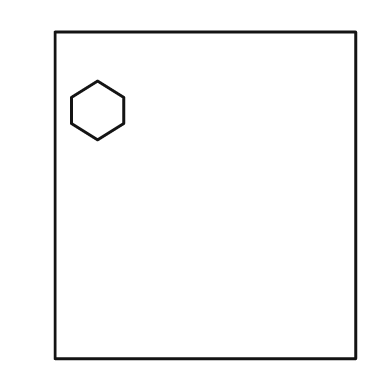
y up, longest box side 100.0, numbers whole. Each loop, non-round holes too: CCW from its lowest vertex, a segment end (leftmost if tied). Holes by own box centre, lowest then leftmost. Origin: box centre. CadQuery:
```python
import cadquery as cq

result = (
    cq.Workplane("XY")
    .moveTo(-46.0, -50.0)
    .lineTo(46.0, -50.0)
    .lineTo(46.0, 50.0)
    .lineTo(-46.0, 50.0)
    .close()
    .moveTo(-33.0, 17.0)
    .lineTo(-25.0, 22.0)
    .lineTo(-25.0, 30.0)
    .lineTo(-33.0, 35.0)
    .lineTo(-41.0, 30.0)
    .lineTo(-41.0, 22.0)
    .close()
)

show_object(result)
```